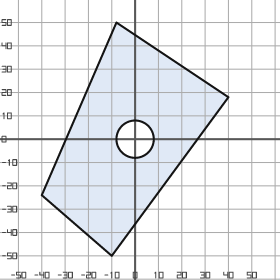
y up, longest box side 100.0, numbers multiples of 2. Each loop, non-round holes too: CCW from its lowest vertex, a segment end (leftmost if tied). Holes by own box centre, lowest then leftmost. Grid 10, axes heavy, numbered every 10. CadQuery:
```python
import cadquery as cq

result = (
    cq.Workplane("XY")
    .moveTo(-10.0, -50.0)
    .lineTo(40.0, 18.0)
    .lineTo(-8.0, 50.0)
    .lineTo(-40.0, -24.0)
    .close()
    .moveTo(0.0, 0.0)
    .circle(8.0)
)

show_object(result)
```